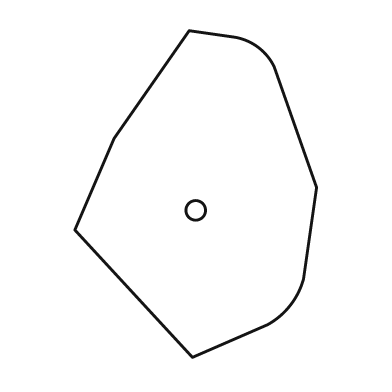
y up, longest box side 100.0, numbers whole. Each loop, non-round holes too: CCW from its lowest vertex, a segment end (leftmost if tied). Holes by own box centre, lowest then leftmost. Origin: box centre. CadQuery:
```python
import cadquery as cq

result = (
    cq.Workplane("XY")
    .moveTo(-1.0, -50.0)
    .lineTo(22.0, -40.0)
    .threePointArc((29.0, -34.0), (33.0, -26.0))
    .lineTo(37.0, 2.0)
    .lineTo(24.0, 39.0)
    .threePointArc((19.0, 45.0), (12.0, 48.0))
    .lineTo(-2.0, 50.0)
    .lineTo(-25.0, 17.0)
    .lineTo(-37.0, -11.0)
    .close()
    .moveTo(0.0, -5.0)
    .circle(3.0)
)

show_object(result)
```